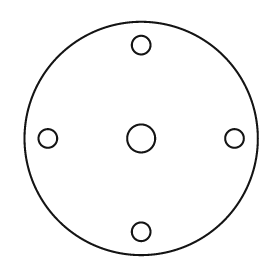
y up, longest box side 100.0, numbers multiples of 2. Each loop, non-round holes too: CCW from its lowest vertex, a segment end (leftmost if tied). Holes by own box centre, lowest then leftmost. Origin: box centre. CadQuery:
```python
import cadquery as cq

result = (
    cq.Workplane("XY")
    .moveTo(0.0, 0.0)
    .circle(50.0)
    .moveTo(0.0, -40.0)
    .circle(4.0)
    .moveTo(-40.0, 0.0)
    .circle(4.0)
    .moveTo(0.0, 0.0)
    .circle(6.0)
    .moveTo(40.0, 0.0)
    .circle(4.0)
    .moveTo(0.0, 40.0)
    .circle(4.0)
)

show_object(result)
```